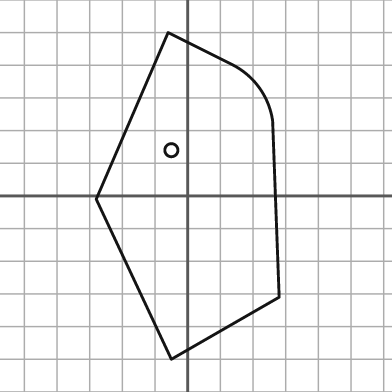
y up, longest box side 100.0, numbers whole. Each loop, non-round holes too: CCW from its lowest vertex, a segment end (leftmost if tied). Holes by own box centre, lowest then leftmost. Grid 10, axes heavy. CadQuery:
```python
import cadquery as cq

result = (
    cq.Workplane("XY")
    .moveTo(-5.0, -50.0)
    .lineTo(28.0, -31.0)
    .lineTo(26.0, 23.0)
    .threePointArc((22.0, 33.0), (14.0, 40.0))
    .lineTo(-6.0, 50.0)
    .lineTo(-28.0, -1.0)
    .close()
    .moveTo(-5.0, 14.0)
    .circle(2.0)
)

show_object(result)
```